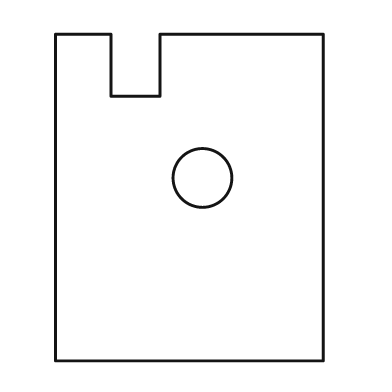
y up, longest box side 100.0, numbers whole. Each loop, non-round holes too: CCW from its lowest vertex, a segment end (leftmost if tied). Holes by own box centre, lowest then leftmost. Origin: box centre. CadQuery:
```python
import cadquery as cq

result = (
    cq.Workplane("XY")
    .moveTo(-41.0, -50.0)
    .lineTo(41.0, -50.0)
    .lineTo(41.0, 50.0)
    .lineTo(-9.0, 50.0)
    .lineTo(-9.0, 31.0)
    .lineTo(-24.0, 31.0)
    .lineTo(-24.0, 50.0)
    .lineTo(-41.0, 50.0)
    .close()
    .moveTo(4.0, 6.0)
    .circle(9.0)
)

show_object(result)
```